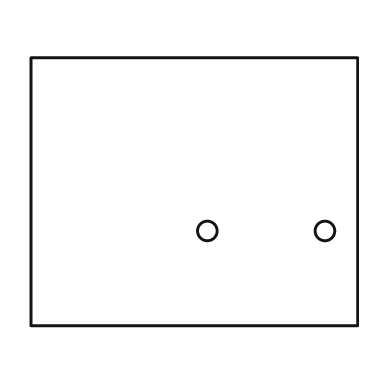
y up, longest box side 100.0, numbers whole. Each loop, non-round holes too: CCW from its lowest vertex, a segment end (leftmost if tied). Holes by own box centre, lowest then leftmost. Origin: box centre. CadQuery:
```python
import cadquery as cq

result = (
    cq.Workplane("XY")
    .moveTo(-50.0, -41.0)
    .lineTo(50.0, -41.0)
    .lineTo(50.0, 41.0)
    .lineTo(-50.0, 41.0)
    .close()
    .moveTo(4.0, -12.0)
    .circle(3.0)
    .moveTo(40.0, -12.0)
    .circle(3.0)
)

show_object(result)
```